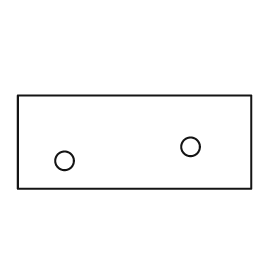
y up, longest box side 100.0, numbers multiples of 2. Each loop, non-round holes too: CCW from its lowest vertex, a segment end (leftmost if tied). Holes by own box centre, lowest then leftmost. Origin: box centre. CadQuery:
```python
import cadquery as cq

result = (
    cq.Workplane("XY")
    .moveTo(-50.0, -20.0)
    .lineTo(50.0, -20.0)
    .lineTo(50.0, 20.0)
    .lineTo(-50.0, 20.0)
    .close()
    .moveTo(-30.0, -8.0)
    .circle(4.0)
    .moveTo(24.0, -2.0)
    .circle(4.0)
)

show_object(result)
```